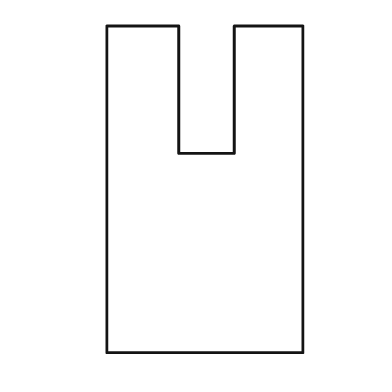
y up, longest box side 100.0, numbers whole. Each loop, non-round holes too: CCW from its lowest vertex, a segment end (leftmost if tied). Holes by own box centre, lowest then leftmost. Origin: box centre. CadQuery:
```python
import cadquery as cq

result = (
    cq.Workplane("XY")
    .moveTo(-30.0, -50.0)
    .lineTo(30.0, -50.0)
    .lineTo(30.0, 50.0)
    .lineTo(9.0, 50.0)
    .lineTo(9.0, 11.0)
    .lineTo(-8.0, 11.0)
    .lineTo(-8.0, 50.0)
    .lineTo(-30.0, 50.0)
    .close()
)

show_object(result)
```